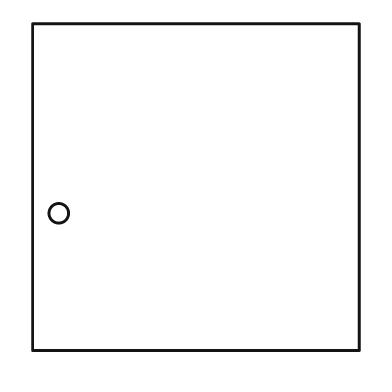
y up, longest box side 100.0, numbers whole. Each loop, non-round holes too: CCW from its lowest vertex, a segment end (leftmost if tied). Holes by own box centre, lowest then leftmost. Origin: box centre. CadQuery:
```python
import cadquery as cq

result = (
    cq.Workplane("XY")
    .moveTo(-50.0, -50.0)
    .lineTo(50.0, -50.0)
    .lineTo(50.0, 50.0)
    .lineTo(-50.0, 50.0)
    .close()
    .moveTo(-42.0, -8.0)
    .circle(3.0)
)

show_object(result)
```